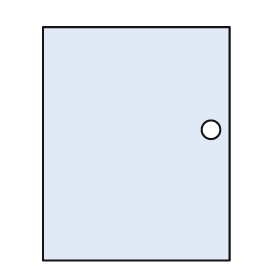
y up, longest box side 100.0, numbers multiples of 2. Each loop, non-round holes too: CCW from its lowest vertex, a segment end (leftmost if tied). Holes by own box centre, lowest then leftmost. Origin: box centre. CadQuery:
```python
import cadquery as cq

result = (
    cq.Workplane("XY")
    .moveTo(-40.0, -50.0)
    .lineTo(40.0, -50.0)
    .lineTo(40.0, 50.0)
    .lineTo(-40.0, 50.0)
    .close()
    .moveTo(32.0, 6.0)
    .circle(4.0)
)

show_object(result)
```